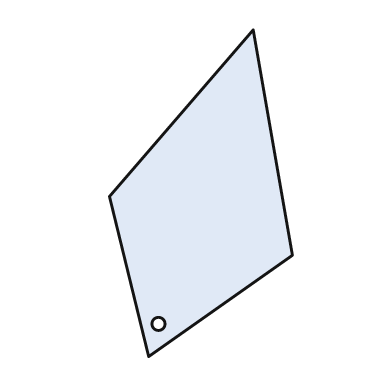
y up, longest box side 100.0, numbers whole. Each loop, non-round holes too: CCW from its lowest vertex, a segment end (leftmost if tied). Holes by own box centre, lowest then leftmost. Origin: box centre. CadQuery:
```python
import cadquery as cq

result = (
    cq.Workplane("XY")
    .moveTo(-16.0, -50.0)
    .lineTo(28.0, -19.0)
    .lineTo(16.0, 50.0)
    .lineTo(-28.0, -1.0)
    .close()
    .moveTo(-13.0, -40.0)
    .circle(2.0)
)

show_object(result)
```